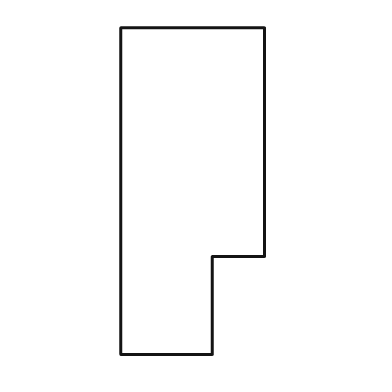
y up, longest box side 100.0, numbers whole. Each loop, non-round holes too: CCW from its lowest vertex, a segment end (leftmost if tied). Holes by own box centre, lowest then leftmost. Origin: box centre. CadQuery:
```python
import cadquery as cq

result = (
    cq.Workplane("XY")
    .moveTo(-22.0, -50.0)
    .lineTo(6.0, -50.0)
    .lineTo(6.0, -20.0)
    .lineTo(22.0, -20.0)
    .lineTo(22.0, 50.0)
    .lineTo(-22.0, 50.0)
    .close()
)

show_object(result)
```